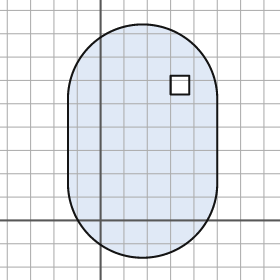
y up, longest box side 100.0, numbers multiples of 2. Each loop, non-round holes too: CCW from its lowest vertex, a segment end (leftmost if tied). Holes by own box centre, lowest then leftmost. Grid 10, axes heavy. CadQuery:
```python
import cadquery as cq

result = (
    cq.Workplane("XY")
    .moveTo(-14.0, 16.0)
    .threePointArc((18.0, -16.0), (50.0, 16.0))
    .lineTo(50.0, 52.0)
    .threePointArc((18.0, 84.0), (-14.0, 52.0))
    .close()
    .moveTo(30.0, 54.0)
    .lineTo(38.0, 54.0)
    .lineTo(38.0, 62.0)
    .lineTo(30.0, 62.0)
    .close()
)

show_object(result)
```